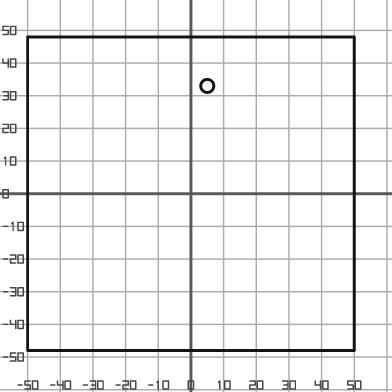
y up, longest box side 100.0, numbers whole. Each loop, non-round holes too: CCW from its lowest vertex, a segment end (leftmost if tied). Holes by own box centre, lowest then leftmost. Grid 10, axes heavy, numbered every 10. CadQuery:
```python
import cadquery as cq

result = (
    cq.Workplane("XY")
    .moveTo(-50.0, -48.0)
    .lineTo(50.0, -48.0)
    .lineTo(50.0, 48.0)
    .lineTo(-50.0, 48.0)
    .close()
    .moveTo(5.0, 33.0)
    .circle(2.0)
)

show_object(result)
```